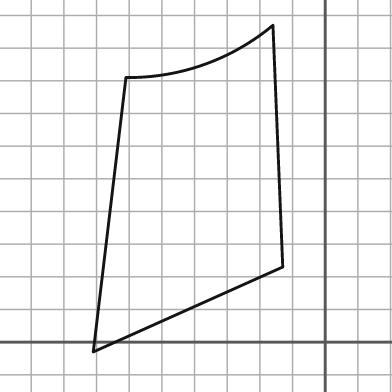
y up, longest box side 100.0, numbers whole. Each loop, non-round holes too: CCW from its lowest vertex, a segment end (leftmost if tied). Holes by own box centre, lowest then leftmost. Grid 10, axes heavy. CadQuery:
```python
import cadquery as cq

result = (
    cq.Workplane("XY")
    .moveTo(-71.0, -3.0)
    .lineTo(-13.0, 23.0)
    .lineTo(-16.0, 97.0)
    .threePointArc((-37.0, 85.0), (-61.0, 81.0))
    .close()
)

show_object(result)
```